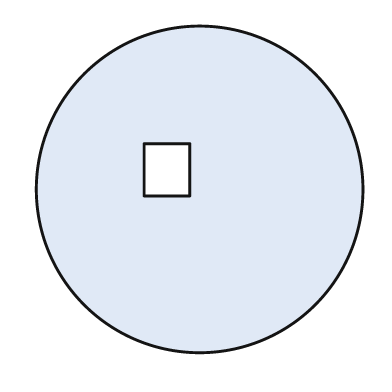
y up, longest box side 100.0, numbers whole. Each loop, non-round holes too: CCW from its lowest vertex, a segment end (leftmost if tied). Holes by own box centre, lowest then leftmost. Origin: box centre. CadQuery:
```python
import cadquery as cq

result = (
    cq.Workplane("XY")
    .moveTo(0.0, 0.0)
    .circle(50.0)
    .moveTo(-17.0, -2.0)
    .lineTo(-3.0, -2.0)
    .lineTo(-3.0, 14.0)
    .lineTo(-17.0, 14.0)
    .close()
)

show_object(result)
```